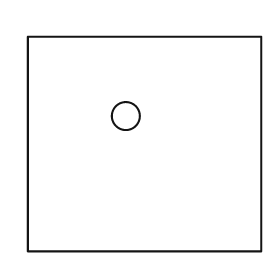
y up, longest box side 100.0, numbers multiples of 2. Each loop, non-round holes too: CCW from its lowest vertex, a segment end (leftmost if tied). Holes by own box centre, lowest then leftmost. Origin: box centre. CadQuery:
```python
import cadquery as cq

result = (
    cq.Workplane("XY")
    .moveTo(-50.0, -46.0)
    .lineTo(50.0, -46.0)
    .lineTo(50.0, 46.0)
    .lineTo(-50.0, 46.0)
    .close()
    .moveTo(-8.0, 12.0)
    .circle(6.0)
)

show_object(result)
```